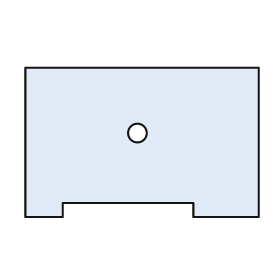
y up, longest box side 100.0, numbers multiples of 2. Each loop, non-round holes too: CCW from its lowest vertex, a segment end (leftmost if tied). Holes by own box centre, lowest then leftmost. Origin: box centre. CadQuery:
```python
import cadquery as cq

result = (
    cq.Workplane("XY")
    .moveTo(-50.0, -32.0)
    .lineTo(-34.0, -32.0)
    .lineTo(-34.0, -26.0)
    .lineTo(22.0, -26.0)
    .lineTo(22.0, -32.0)
    .lineTo(50.0, -32.0)
    .lineTo(50.0, 32.0)
    .lineTo(-50.0, 32.0)
    .close()
    .moveTo(-2.0, 4.0)
    .circle(4.0)
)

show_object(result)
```